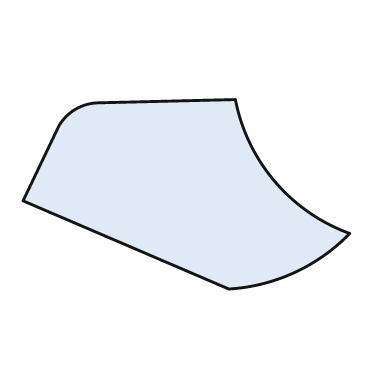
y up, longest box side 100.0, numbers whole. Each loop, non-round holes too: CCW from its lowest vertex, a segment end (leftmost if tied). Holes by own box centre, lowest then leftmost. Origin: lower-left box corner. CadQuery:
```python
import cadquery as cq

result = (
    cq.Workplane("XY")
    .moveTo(63.0, 0.0)
    .threePointArc((83.0, 5.0), (100.0, 17.0))
    .threePointArc((77.0, 33.0), (65.0, 58.0))
    .lineTo(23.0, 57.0)
    .threePointArc((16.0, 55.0), (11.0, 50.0))
    .lineTo(0.0, 27.0)
    .close()
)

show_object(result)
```